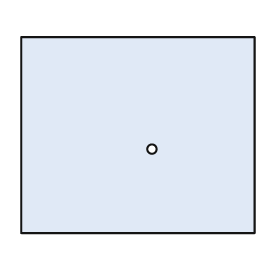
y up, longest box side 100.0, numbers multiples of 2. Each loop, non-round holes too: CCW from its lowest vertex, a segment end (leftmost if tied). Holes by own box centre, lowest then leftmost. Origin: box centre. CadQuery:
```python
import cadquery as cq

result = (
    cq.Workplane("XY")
    .moveTo(-50.0, -42.0)
    .lineTo(50.0, -42.0)
    .lineTo(50.0, 42.0)
    .lineTo(-50.0, 42.0)
    .close()
    .moveTo(6.0, -6.0)
    .circle(2.0)
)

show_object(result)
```